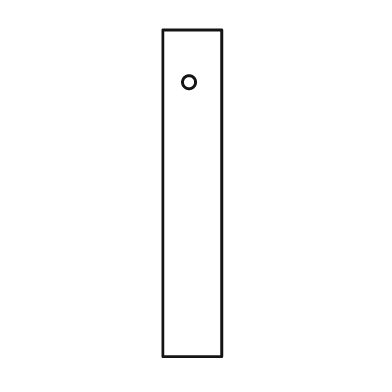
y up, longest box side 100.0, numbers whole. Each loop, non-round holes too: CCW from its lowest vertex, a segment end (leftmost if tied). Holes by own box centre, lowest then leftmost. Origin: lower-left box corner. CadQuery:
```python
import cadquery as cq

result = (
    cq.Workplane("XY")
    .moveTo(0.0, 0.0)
    .lineTo(18.0, 0.0)
    .lineTo(18.0, 100.0)
    .lineTo(0.0, 100.0)
    .close()
    .moveTo(8.0, 84.0)
    .circle(2.0)
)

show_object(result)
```